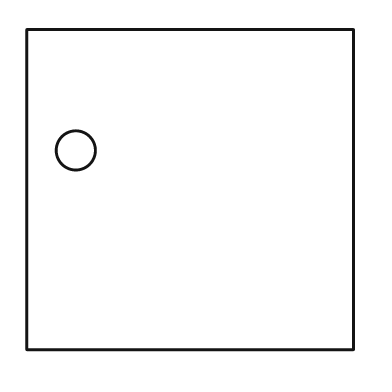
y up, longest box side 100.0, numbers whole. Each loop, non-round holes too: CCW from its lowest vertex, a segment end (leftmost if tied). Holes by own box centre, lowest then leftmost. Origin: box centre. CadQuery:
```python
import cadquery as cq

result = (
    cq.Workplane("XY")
    .moveTo(-50.0, -49.0)
    .lineTo(50.0, -49.0)
    .lineTo(50.0, 49.0)
    .lineTo(-50.0, 49.0)
    .close()
    .moveTo(-35.0, 12.0)
    .circle(6.0)
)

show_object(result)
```